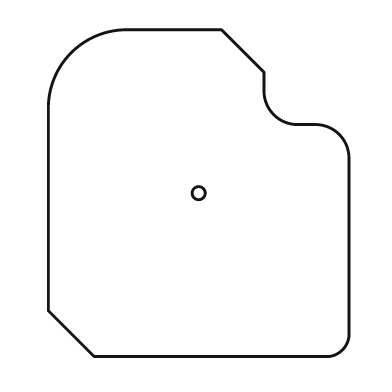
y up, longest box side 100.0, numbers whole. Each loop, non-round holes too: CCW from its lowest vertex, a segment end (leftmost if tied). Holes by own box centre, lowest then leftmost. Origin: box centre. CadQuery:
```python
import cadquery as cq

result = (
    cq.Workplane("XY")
    .moveTo(-32.0, -50.0)
    .lineTo(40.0, -50.0)
    .threePointArc((44.0, -48.0), (46.0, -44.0))
    .lineTo(46.0, 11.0)
    .threePointArc((43.0, 18.0), (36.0, 21.0))
    .lineTo(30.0, 21.0)
    .threePointArc((23.0, 24.0), (20.0, 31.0))
    .lineTo(20.0, 37.0)
    .lineTo(7.0, 50.0)
    .lineTo(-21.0, 50.0)
    .threePointArc((-39.0, 43.0), (-46.0, 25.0))
    .lineTo(-46.0, -36.0)
    .close()
    .moveTo(0.0, 0.0)
    .circle(2.0)
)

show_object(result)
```